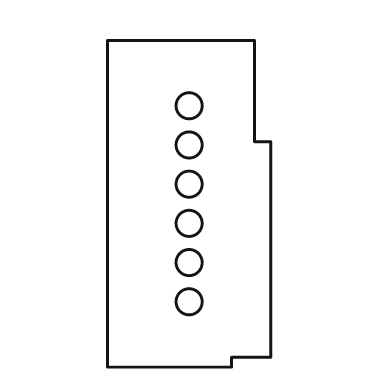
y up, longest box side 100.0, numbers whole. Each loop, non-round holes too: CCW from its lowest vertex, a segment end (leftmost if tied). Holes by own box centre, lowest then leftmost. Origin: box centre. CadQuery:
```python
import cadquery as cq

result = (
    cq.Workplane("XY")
    .moveTo(-25.0, -50.0)
    .lineTo(13.0, -50.0)
    .lineTo(13.0, -47.0)
    .lineTo(25.0, -47.0)
    .lineTo(25.0, 19.0)
    .lineTo(20.0, 19.0)
    .lineTo(20.0, 50.0)
    .lineTo(-25.0, 50.0)
    .close()
    .moveTo(0.0, -30.0)
    .circle(4.0)
    .moveTo(0.0, -18.0)
    .circle(4.0)
    .moveTo(0.0, -6.0)
    .circle(4.0)
    .moveTo(0.0, 6.0)
    .circle(4.0)
    .moveTo(0.0, 18.0)
    .circle(4.0)
    .moveTo(0.0, 30.0)
    .circle(4.0)
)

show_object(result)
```